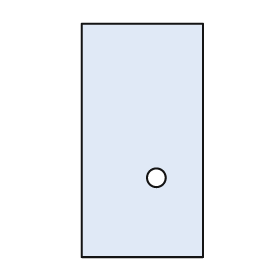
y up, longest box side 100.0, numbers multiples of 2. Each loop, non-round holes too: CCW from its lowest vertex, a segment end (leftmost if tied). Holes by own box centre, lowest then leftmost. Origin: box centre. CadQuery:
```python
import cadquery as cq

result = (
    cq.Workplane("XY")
    .moveTo(-26.0, -50.0)
    .lineTo(26.0, -50.0)
    .lineTo(26.0, 50.0)
    .lineTo(-26.0, 50.0)
    .close()
    .moveTo(6.0, -16.0)
    .circle(4.0)
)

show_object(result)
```